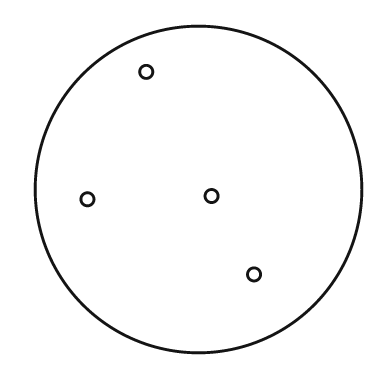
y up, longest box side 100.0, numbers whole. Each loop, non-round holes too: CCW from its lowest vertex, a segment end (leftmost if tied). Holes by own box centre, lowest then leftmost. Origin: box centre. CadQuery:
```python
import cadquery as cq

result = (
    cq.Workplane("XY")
    .moveTo(0.0, 0.0)
    .circle(50.0)
    .moveTo(17.0, -26.0)
    .circle(2.0)
    .moveTo(-34.0, -3.0)
    .circle(2.0)
    .moveTo(4.0, -2.0)
    .circle(2.0)
    .moveTo(-16.0, 36.0)
    .circle(2.0)
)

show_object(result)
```